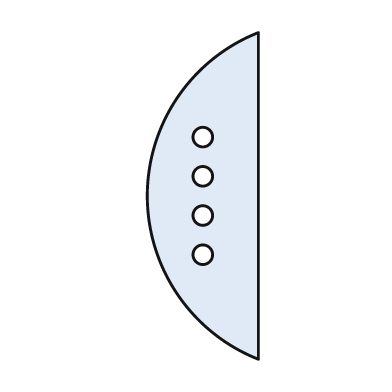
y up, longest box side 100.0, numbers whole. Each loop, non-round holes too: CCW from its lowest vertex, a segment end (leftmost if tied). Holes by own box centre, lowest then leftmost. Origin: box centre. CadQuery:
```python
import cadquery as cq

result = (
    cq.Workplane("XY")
    .moveTo(17.0, -50.0)
    .lineTo(17.0, 50.0)
    .threePointArc((-17.0, 0.0), (17.0, -50.0))
    .close()
    .moveTo(0.0, -18.0)
    .circle(3.0)
    .moveTo(0.0, -6.0)
    .circle(3.0)
    .moveTo(0.0, 6.0)
    .circle(3.0)
    .moveTo(0.0, 18.0)
    .circle(3.0)
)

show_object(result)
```